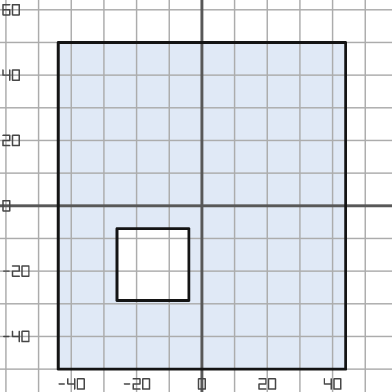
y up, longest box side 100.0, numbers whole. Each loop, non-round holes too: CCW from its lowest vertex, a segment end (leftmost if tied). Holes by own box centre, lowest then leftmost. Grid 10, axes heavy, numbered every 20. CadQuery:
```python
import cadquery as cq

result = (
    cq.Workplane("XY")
    .moveTo(-44.0, -50.0)
    .lineTo(44.0, -50.0)
    .lineTo(44.0, 50.0)
    .lineTo(-44.0, 50.0)
    .close()
    .moveTo(-26.0, -29.0)
    .lineTo(-4.0, -29.0)
    .lineTo(-4.0, -7.0)
    .lineTo(-26.0, -7.0)
    .close()
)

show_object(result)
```